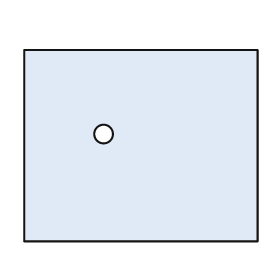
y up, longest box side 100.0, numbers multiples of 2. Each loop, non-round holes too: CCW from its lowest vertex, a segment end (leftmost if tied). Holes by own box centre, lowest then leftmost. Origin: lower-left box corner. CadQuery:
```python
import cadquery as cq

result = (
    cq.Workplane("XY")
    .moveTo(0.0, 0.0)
    .lineTo(100.0, 0.0)
    .lineTo(100.0, 82.0)
    .lineTo(0.0, 82.0)
    .close()
    .moveTo(34.0, 46.0)
    .circle(4.0)
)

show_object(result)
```